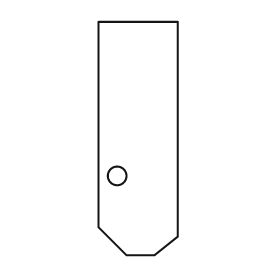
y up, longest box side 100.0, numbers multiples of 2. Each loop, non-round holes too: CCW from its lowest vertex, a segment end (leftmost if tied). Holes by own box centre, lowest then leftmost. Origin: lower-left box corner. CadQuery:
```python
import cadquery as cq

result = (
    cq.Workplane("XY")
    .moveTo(12.0, 0.0)
    .lineTo(24.0, 0.0)
    .lineTo(34.0, 8.0)
    .lineTo(34.0, 100.0)
    .lineTo(0.0, 100.0)
    .lineTo(0.0, 12.0)
    .close()
    .moveTo(8.0, 34.0)
    .circle(4.0)
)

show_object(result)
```